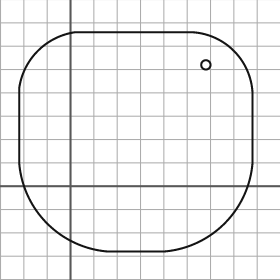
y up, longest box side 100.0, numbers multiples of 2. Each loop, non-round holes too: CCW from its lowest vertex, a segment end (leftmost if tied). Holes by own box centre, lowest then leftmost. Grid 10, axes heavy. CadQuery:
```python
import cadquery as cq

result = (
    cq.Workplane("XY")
    .moveTo(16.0, -28.0)
    .lineTo(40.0, -28.0)
    .threePointArc((66.0, -16.0), (78.0, 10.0))
    .lineTo(78.0, 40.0)
    .threePointArc((70.0, 58.0), (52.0, 66.0))
    .lineTo(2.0, 66.0)
    .threePointArc((-14.0, 58.0), (-22.0, 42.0))
    .lineTo(-22.0, 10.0)
    .threePointArc((-10.0, -16.0), (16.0, -28.0))
    .close()
    .moveTo(58.0, 52.0)
    .circle(2.0)
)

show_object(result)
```